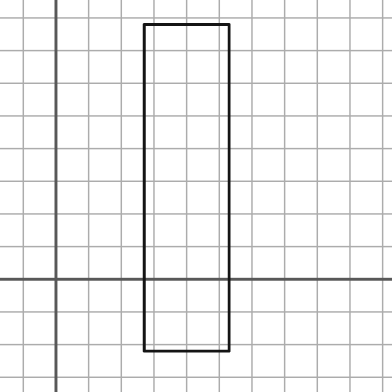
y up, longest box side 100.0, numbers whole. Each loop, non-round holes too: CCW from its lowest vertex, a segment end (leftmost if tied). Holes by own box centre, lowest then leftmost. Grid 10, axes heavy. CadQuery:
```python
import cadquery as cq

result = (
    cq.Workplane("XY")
    .moveTo(27.0, -22.0)
    .lineTo(53.0, -22.0)
    .lineTo(53.0, 78.0)
    .lineTo(27.0, 78.0)
    .close()
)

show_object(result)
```